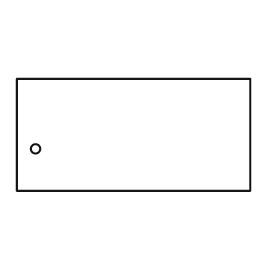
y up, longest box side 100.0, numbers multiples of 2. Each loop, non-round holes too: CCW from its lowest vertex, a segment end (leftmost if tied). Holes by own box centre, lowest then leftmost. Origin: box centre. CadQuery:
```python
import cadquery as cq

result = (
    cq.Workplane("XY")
    .moveTo(-50.0, -24.0)
    .lineTo(50.0, -24.0)
    .lineTo(50.0, 24.0)
    .lineTo(-50.0, 24.0)
    .close()
    .moveTo(-42.0, -6.0)
    .circle(2.0)
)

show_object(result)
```